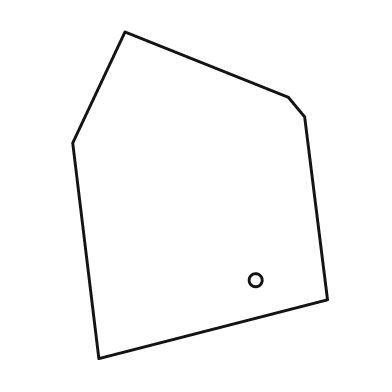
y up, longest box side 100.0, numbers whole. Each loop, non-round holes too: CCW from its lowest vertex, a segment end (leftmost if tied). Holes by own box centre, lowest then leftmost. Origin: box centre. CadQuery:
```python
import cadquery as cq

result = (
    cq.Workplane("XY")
    .moveTo(-31.0, -50.0)
    .lineTo(39.0, -32.0)
    .lineTo(32.0, 24.0)
    .lineTo(27.0, 30.0)
    .lineTo(-23.0, 50.0)
    .lineTo(-39.0, 16.0)
    .close()
    .moveTo(17.0, -26.0)
    .circle(2.0)
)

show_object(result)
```